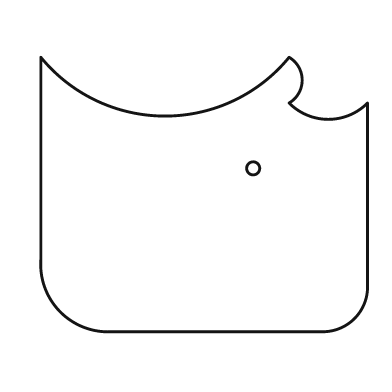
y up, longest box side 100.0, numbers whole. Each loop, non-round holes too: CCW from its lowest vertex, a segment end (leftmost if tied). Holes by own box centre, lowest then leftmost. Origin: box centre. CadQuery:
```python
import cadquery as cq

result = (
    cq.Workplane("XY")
    .moveTo(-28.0, -42.0)
    .lineTo(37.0, -42.0)
    .threePointArc((46.0, -38.0), (50.0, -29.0))
    .lineTo(50.0, 28.0)
    .threePointArc((38.0, 23.0), (26.0, 28.0))
    .threePointArc((30.0, 35.0), (26.0, 42.0))
    .threePointArc((-12.0, 24.0), (-50.0, 42.0))
    .lineTo(-50.0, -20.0)
    .threePointArc((-44.0, -36.0), (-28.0, -42.0))
    .close()
    .moveTo(15.0, 8.0)
    .circle(2.0)
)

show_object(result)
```